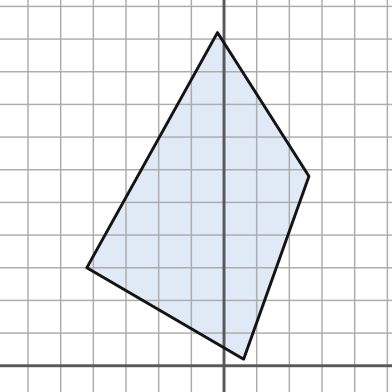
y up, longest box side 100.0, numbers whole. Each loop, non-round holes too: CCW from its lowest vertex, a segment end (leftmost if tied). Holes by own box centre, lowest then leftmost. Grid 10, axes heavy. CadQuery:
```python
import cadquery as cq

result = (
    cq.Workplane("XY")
    .moveTo(6.0, 2.0)
    .lineTo(26.0, 58.0)
    .lineTo(-2.0, 102.0)
    .lineTo(-42.0, 30.0)
    .close()
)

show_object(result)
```